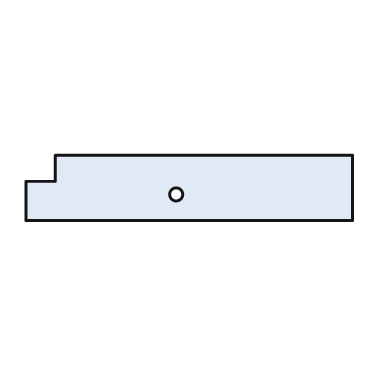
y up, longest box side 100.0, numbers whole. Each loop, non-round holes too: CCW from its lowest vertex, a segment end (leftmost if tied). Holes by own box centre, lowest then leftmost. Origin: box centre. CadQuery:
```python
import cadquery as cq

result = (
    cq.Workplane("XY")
    .moveTo(-50.0, -10.0)
    .lineTo(50.0, -10.0)
    .lineTo(50.0, 10.0)
    .lineTo(-41.0, 10.0)
    .lineTo(-41.0, 2.0)
    .lineTo(-50.0, 2.0)
    .close()
    .moveTo(-4.0, -2.0)
    .circle(2.0)
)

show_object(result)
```